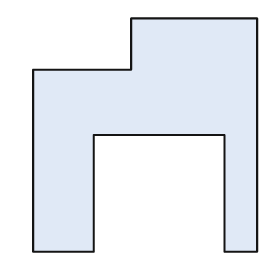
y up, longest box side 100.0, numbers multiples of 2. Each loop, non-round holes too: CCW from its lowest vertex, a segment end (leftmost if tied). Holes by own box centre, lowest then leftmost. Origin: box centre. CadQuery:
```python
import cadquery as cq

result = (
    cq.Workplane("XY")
    .moveTo(-48.0, -50.0)
    .lineTo(-22.0, -50.0)
    .lineTo(-22.0, 0.0)
    .lineTo(34.0, 0.0)
    .lineTo(34.0, -50.0)
    .lineTo(48.0, -50.0)
    .lineTo(48.0, 50.0)
    .lineTo(-6.0, 50.0)
    .lineTo(-6.0, 28.0)
    .lineTo(-48.0, 28.0)
    .close()
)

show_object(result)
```